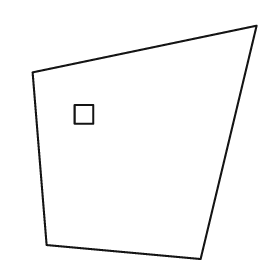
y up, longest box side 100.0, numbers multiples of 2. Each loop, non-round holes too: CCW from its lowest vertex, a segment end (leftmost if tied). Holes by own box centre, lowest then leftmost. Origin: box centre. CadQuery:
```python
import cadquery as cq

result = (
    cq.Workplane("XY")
    .moveTo(24.0, -50.0)
    .lineTo(48.0, 50.0)
    .lineTo(-48.0, 30.0)
    .lineTo(-42.0, -44.0)
    .close()
    .moveTo(-30.0, 8.0)
    .lineTo(-22.0, 8.0)
    .lineTo(-22.0, 16.0)
    .lineTo(-30.0, 16.0)
    .close()
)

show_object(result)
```